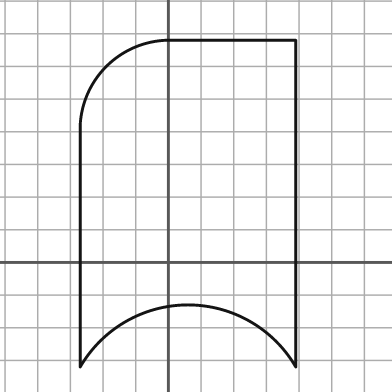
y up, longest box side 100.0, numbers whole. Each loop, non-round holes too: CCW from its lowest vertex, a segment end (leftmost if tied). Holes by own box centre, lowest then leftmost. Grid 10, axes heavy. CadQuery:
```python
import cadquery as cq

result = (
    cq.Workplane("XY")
    .moveTo(-27.0, -32.0)
    .threePointArc((6.0, -13.0), (39.0, -32.0))
    .lineTo(39.0, 68.0)
    .lineTo(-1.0, 68.0)
    .threePointArc((-19.0, 60.0), (-27.0, 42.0))
    .close()
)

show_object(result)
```